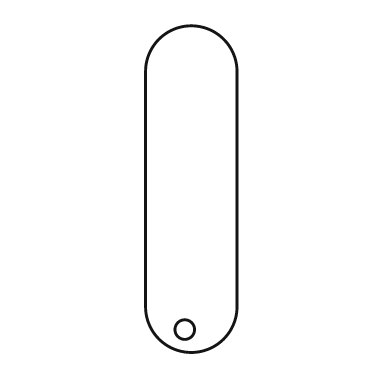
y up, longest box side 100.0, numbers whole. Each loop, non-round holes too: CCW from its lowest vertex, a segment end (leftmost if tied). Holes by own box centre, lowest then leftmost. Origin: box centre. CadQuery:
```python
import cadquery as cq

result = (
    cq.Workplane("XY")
    .moveTo(-14.0, -36.0)
    .threePointArc((0.0, -50.0), (14.0, -36.0))
    .lineTo(14.0, 36.0)
    .threePointArc((0.0, 50.0), (-14.0, 36.0))
    .close()
    .moveTo(-2.0, -43.0)
    .circle(3.0)
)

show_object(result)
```